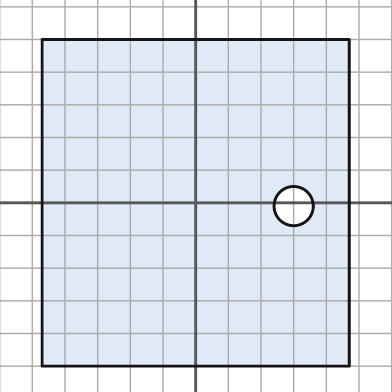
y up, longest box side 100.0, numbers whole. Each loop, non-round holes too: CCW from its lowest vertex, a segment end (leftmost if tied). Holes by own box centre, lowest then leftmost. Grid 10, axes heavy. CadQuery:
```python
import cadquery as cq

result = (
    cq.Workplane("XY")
    .moveTo(-47.0, -50.0)
    .lineTo(47.0, -50.0)
    .lineTo(47.0, 50.0)
    .lineTo(-47.0, 50.0)
    .close()
    .moveTo(30.0, -1.0)
    .circle(6.0)
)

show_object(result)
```